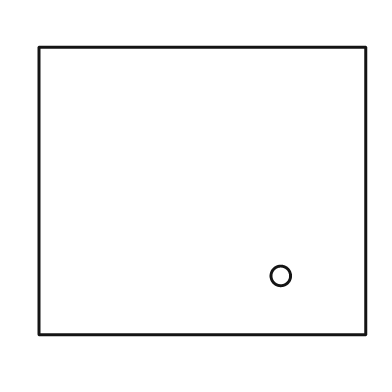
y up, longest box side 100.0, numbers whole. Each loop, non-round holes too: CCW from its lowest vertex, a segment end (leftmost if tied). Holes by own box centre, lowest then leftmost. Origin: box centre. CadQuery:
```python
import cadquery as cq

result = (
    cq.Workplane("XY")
    .moveTo(-50.0, -44.0)
    .lineTo(50.0, -44.0)
    .lineTo(50.0, 44.0)
    .lineTo(-50.0, 44.0)
    .close()
    .moveTo(24.0, -26.0)
    .circle(3.0)
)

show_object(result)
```